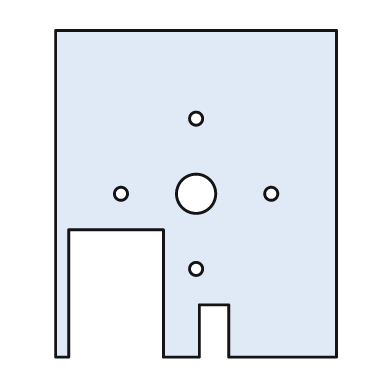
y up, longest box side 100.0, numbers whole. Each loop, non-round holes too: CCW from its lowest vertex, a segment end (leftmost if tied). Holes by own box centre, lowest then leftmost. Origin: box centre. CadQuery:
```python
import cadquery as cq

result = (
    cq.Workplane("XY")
    .moveTo(-43.0, -50.0)
    .lineTo(-39.0, -50.0)
    .lineTo(-39.0, -11.0)
    .lineTo(-10.0, -11.0)
    .lineTo(-10.0, -50.0)
    .lineTo(1.0, -50.0)
    .lineTo(1.0, -34.0)
    .lineTo(10.0, -34.0)
    .lineTo(10.0, -50.0)
    .lineTo(43.0, -50.0)
    .lineTo(43.0, 50.0)
    .lineTo(-43.0, 50.0)
    .close()
    .moveTo(0.0, -23.0)
    .circle(2.0)
    .moveTo(-23.0, 0.0)
    .circle(2.0)
    .moveTo(0.0, 0.0)
    .circle(6.0)
    .moveTo(23.0, 0.0)
    .circle(2.0)
    .moveTo(0.0, 23.0)
    .circle(2.0)
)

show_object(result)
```